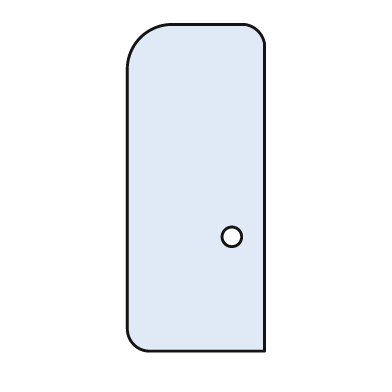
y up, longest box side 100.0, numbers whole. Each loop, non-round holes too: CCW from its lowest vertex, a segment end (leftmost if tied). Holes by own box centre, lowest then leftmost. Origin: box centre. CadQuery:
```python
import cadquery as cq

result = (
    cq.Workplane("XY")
    .moveTo(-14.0, -50.0)
    .lineTo(21.0, -50.0)
    .lineTo(21.0, 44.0)
    .threePointArc((19.0, 48.0), (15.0, 50.0))
    .lineTo(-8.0, 50.0)
    .threePointArc((-17.0, 46.0), (-21.0, 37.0))
    .lineTo(-21.0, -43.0)
    .threePointArc((-19.0, -48.0), (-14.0, -50.0))
    .close()
    .moveTo(11.0, -15.0)
    .circle(3.0)
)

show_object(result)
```